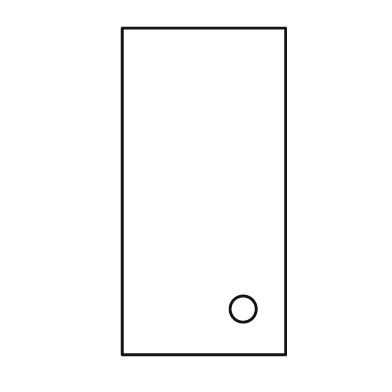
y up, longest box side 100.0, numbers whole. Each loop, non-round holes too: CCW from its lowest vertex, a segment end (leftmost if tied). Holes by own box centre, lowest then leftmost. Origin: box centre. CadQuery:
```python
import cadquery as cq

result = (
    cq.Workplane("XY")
    .moveTo(-25.0, -50.0)
    .lineTo(25.0, -50.0)
    .lineTo(25.0, 50.0)
    .lineTo(-25.0, 50.0)
    .close()
    .moveTo(12.0, -36.0)
    .circle(4.0)
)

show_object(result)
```